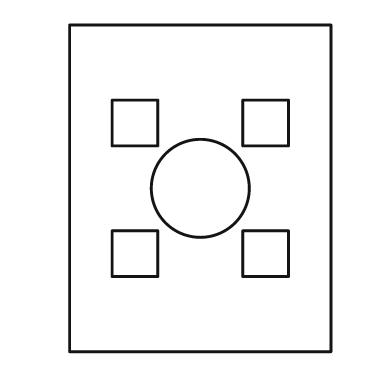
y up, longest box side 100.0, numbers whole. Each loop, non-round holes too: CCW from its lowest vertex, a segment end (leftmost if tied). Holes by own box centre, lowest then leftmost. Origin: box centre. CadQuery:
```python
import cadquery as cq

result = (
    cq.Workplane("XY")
    .moveTo(-40.0, -50.0)
    .lineTo(40.0, -50.0)
    .lineTo(40.0, 50.0)
    .lineTo(-40.0, 50.0)
    .close()
    .moveTo(-27.0, -27.0)
    .lineTo(-13.0, -27.0)
    .lineTo(-13.0, -13.0)
    .lineTo(-27.0, -13.0)
    .close()
    .moveTo(13.0, -27.0)
    .lineTo(27.0, -27.0)
    .lineTo(27.0, -13.0)
    .lineTo(13.0, -13.0)
    .close()
    .moveTo(0.0, 0.0)
    .circle(15.0)
    .moveTo(-27.0, 13.0)
    .lineTo(-13.0, 13.0)
    .lineTo(-13.0, 27.0)
    .lineTo(-27.0, 27.0)
    .close()
    .moveTo(13.0, 13.0)
    .lineTo(27.0, 13.0)
    .lineTo(27.0, 27.0)
    .lineTo(13.0, 27.0)
    .close()
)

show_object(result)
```